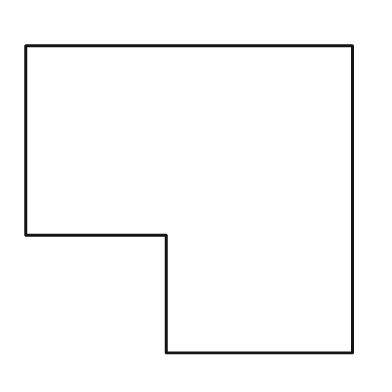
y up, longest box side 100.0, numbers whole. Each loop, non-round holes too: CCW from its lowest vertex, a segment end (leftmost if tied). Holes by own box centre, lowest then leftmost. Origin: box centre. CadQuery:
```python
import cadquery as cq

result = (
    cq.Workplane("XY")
    .moveTo(-7.0, -47.0)
    .lineTo(50.0, -47.0)
    .lineTo(50.0, 47.0)
    .lineTo(-50.0, 47.0)
    .lineTo(-50.0, -11.0)
    .lineTo(-7.0, -11.0)
    .close()
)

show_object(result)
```